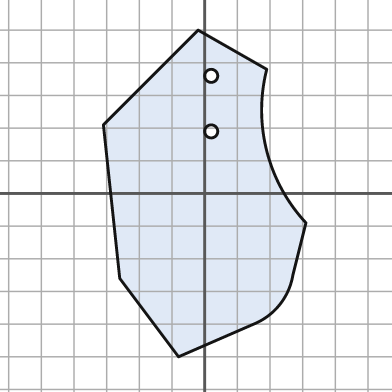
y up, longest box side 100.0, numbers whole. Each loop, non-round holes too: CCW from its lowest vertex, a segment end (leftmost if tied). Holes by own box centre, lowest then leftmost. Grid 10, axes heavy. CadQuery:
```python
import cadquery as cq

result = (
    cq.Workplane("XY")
    .moveTo(-8.0, -50.0)
    .lineTo(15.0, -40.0)
    .threePointArc((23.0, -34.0), (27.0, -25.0))
    .lineTo(31.0, -9.0)
    .threePointArc((19.0, 13.0), (19.0, 38.0))
    .lineTo(-2.0, 50.0)
    .lineTo(-31.0, 21.0)
    .lineTo(-26.0, -26.0)
    .close()
    .moveTo(2.0, 19.0)
    .circle(2.0)
    .moveTo(2.0, 36.0)
    .circle(2.0)
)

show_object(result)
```